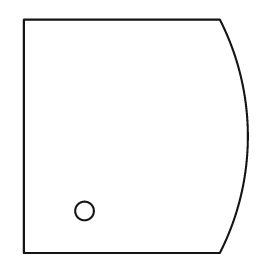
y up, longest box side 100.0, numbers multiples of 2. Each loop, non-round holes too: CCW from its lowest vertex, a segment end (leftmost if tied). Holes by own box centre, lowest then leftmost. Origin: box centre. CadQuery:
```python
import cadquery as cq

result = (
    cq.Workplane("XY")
    .moveTo(-48.0, -50.0)
    .lineTo(36.0, -50.0)
    .threePointArc((48.0, 0.0), (36.0, 50.0))
    .lineTo(-48.0, 50.0)
    .close()
    .moveTo(-22.0, -32.0)
    .circle(4.0)
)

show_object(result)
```